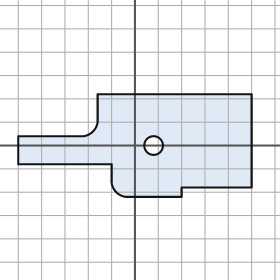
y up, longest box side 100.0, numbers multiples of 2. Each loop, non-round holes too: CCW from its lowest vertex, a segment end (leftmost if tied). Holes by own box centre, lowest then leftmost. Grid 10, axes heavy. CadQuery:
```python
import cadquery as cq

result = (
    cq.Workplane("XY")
    .moveTo(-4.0, -22.0)
    .lineTo(20.0, -22.0)
    .lineTo(20.0, -18.0)
    .lineTo(50.0, -18.0)
    .lineTo(50.0, 22.0)
    .lineTo(-16.0, 22.0)
    .lineTo(-16.0, 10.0)
    .threePointArc((-18.0, 6.0), (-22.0, 4.0))
    .lineTo(-50.0, 4.0)
    .lineTo(-50.0, -8.0)
    .lineTo(-10.0, -8.0)
    .lineTo(-10.0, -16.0)
    .threePointArc((-8.0, -20.0), (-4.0, -22.0))
    .close()
    .moveTo(8.0, 0.0)
    .circle(4.0)
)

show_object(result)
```